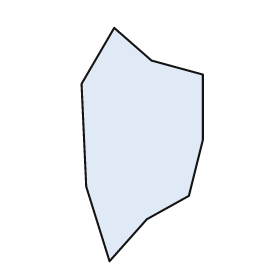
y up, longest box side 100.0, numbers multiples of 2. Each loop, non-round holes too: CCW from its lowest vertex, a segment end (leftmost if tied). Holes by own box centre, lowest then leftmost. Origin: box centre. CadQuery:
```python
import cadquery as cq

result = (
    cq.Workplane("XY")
    .moveTo(-14.0, -50.0)
    .lineTo(2.0, -32.0)
    .lineTo(20.0, -22.0)
    .lineTo(26.0, 2.0)
    .lineTo(26.0, 30.0)
    .lineTo(4.0, 36.0)
    .lineTo(-12.0, 50.0)
    .lineTo(-26.0, 26.0)
    .lineTo(-24.0, -18.0)
    .close()
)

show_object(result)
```